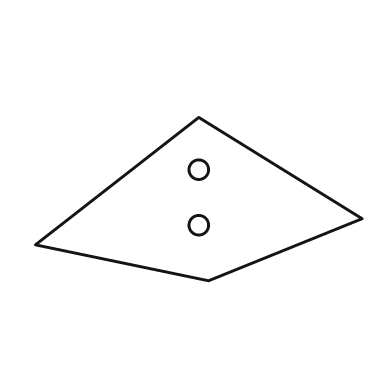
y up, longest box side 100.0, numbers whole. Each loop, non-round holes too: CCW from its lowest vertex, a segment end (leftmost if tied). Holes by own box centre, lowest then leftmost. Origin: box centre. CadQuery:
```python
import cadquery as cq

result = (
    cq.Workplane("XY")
    .moveTo(3.0, -25.0)
    .lineTo(50.0, -6.0)
    .lineTo(0.0, 25.0)
    .lineTo(-50.0, -14.0)
    .close()
    .moveTo(0.0, -8.0)
    .circle(3.0)
    .moveTo(0.0, 9.0)
    .circle(3.0)
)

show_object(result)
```